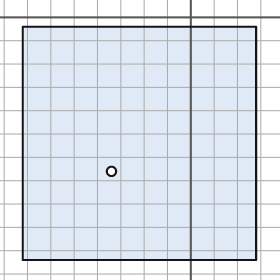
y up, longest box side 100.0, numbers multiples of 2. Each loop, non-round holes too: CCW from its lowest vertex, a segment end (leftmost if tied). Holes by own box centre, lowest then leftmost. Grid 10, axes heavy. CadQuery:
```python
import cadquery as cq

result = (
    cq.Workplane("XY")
    .moveTo(-72.0, -104.0)
    .lineTo(28.0, -104.0)
    .lineTo(28.0, -4.0)
    .lineTo(-72.0, -4.0)
    .close()
    .moveTo(-34.0, -66.0)
    .circle(2.0)
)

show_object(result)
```